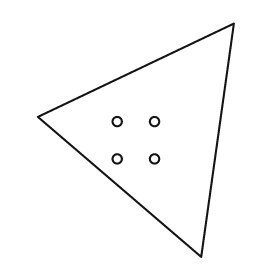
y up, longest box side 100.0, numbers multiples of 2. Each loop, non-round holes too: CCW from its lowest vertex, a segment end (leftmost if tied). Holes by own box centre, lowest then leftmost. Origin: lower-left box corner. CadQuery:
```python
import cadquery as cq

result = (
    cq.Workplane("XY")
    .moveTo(70.0, 0.0)
    .lineTo(84.0, 100.0)
    .lineTo(0.0, 60.0)
    .close()
    .moveTo(34.0, 42.0)
    .circle(2.0)
    .moveTo(50.0, 42.0)
    .circle(2.0)
    .moveTo(34.0, 58.0)
    .circle(2.0)
    .moveTo(50.0, 58.0)
    .circle(2.0)
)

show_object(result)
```